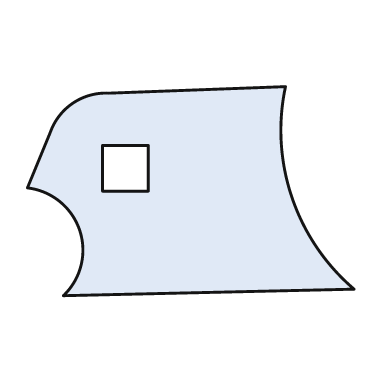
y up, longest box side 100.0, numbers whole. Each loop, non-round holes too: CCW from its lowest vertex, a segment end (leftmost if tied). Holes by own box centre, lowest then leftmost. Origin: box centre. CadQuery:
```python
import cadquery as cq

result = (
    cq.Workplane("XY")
    .moveTo(-39.0, -32.0)
    .lineTo(50.0, -30.0)
    .threePointArc((31.0, -2.0), (29.0, 32.0))
    .lineTo(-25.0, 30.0)
    .threePointArc((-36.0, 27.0), (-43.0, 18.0))
    .lineTo(-50.0, 1.0)
    .threePointArc((-34.0, -12.0), (-39.0, -32.0))
    .close()
    .moveTo(-27.0, 0.0)
    .lineTo(-13.0, 0.0)
    .lineTo(-13.0, 14.0)
    .lineTo(-27.0, 14.0)
    .close()
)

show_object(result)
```